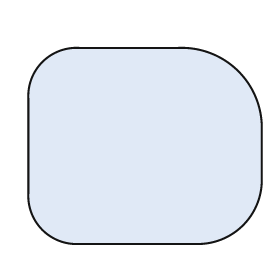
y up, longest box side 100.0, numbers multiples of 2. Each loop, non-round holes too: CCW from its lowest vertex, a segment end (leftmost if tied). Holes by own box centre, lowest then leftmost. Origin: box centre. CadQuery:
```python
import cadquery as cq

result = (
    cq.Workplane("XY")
    .moveTo(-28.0, -42.0)
    .lineTo(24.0, -42.0)
    .threePointArc((42.0, -34.0), (50.0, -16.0))
    .lineTo(50.0, 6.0)
    .threePointArc((40.0, 32.0), (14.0, 42.0))
    .lineTo(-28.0, 42.0)
    .threePointArc((-44.0, 36.0), (-50.0, 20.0))
    .lineTo(-50.0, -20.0)
    .threePointArc((-44.0, -36.0), (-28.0, -42.0))
    .close()
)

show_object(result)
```